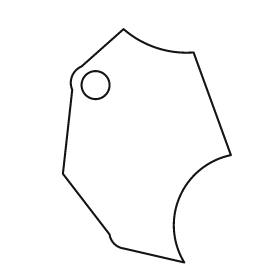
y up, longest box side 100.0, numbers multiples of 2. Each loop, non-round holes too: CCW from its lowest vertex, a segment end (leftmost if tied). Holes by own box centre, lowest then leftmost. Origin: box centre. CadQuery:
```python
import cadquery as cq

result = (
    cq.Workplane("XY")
    .moveTo(16.0, -50.0)
    .threePointArc((14.0, -22.0), (36.0, -4.0))
    .lineTo(20.0, 40.0)
    .threePointArc((4.0, 42.0), (-10.0, 50.0))
    .lineTo(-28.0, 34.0)
    .threePointArc((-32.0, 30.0), (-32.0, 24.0))
    .lineTo(-36.0, -12.0)
    .lineTo(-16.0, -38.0)
    .threePointArc((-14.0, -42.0), (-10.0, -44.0))
    .close()
    .moveTo(-22.0, 26.0)
    .circle(6.0)
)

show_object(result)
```